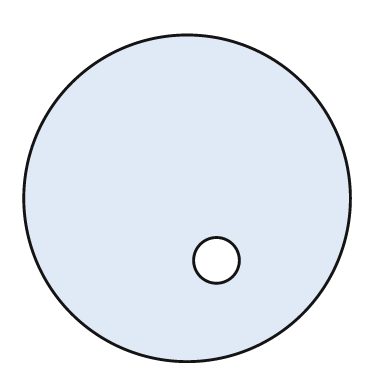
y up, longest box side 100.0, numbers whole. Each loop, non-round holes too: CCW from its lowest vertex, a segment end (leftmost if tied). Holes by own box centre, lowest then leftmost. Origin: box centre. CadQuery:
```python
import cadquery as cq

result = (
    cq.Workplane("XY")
    .moveTo(0.0, 0.0)
    .circle(50.0)
    .moveTo(9.0, -19.0)
    .circle(7.0)
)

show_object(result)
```